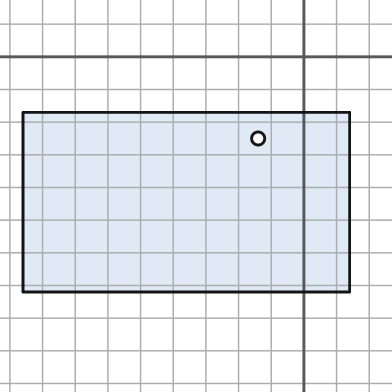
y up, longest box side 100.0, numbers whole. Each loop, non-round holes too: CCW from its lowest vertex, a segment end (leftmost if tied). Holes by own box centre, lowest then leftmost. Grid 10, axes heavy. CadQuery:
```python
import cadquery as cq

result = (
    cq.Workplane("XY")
    .moveTo(-86.0, -72.0)
    .lineTo(14.0, -72.0)
    .lineTo(14.0, -17.0)
    .lineTo(-86.0, -17.0)
    .close()
    .moveTo(-14.0, -25.0)
    .circle(2.0)
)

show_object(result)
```